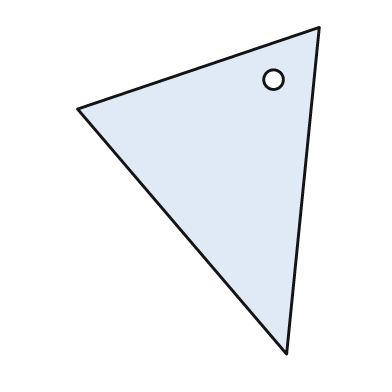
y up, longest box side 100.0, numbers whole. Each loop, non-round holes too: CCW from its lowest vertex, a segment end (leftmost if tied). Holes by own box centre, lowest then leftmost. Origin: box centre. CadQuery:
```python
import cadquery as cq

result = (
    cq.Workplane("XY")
    .moveTo(27.0, -50.0)
    .lineTo(37.0, 50.0)
    .lineTo(-37.0, 25.0)
    .close()
    .moveTo(23.0, 34.0)
    .circle(3.0)
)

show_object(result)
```